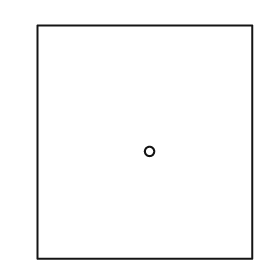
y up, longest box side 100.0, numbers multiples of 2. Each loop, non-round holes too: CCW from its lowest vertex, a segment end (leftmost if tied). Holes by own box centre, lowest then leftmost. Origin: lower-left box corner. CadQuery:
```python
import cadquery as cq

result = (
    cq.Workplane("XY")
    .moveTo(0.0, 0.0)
    .lineTo(92.0, 0.0)
    .lineTo(92.0, 100.0)
    .lineTo(0.0, 100.0)
    .close()
    .moveTo(48.0, 46.0)
    .circle(2.0)
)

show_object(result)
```